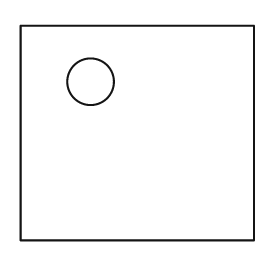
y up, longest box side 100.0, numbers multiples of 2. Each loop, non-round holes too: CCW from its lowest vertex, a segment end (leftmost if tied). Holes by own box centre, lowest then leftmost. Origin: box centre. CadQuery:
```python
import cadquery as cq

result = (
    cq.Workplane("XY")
    .moveTo(-50.0, -46.0)
    .lineTo(50.0, -46.0)
    .lineTo(50.0, 46.0)
    .lineTo(-50.0, 46.0)
    .close()
    .moveTo(-20.0, 22.0)
    .circle(10.0)
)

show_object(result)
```